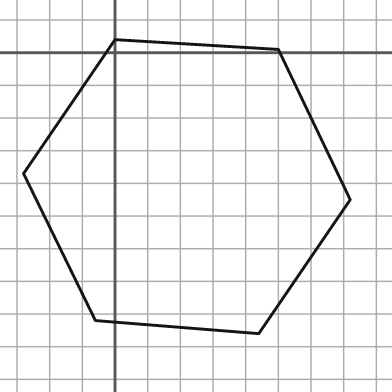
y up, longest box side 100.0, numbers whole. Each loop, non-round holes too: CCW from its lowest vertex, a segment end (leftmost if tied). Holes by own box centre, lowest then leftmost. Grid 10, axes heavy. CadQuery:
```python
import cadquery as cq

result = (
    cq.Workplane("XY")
    .moveTo(44.0, -86.0)
    .lineTo(72.0, -45.0)
    .lineTo(50.0, 1.0)
    .lineTo(0.0, 4.0)
    .lineTo(-28.0, -37.0)
    .lineTo(-6.0, -82.0)
    .close()
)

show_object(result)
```